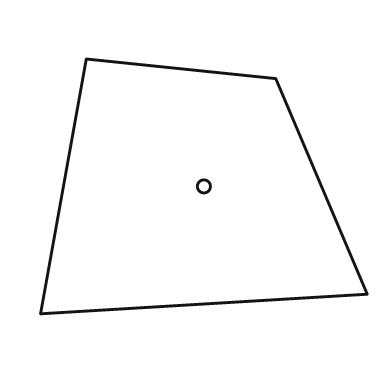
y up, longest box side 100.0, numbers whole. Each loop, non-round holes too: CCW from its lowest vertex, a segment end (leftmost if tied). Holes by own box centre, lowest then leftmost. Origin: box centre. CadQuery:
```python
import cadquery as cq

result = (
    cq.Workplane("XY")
    .moveTo(-50.0, -39.0)
    .lineTo(50.0, -33.0)
    .lineTo(22.0, 33.0)
    .lineTo(-36.0, 39.0)
    .close()
    .moveTo(0.0, 0.0)
    .circle(2.0)
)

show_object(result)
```